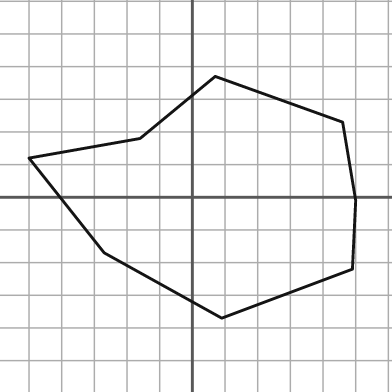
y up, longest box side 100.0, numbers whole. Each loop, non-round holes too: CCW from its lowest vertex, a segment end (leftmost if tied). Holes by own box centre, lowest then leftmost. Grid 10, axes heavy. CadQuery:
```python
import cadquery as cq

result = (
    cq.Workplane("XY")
    .moveTo(9.0, -37.0)
    .lineTo(49.0, -22.0)
    .lineTo(50.0, -1.0)
    .lineTo(46.0, 23.0)
    .lineTo(7.0, 37.0)
    .lineTo(-16.0, 18.0)
    .lineTo(-50.0, 12.0)
    .lineTo(-27.0, -17.0)
    .close()
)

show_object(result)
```